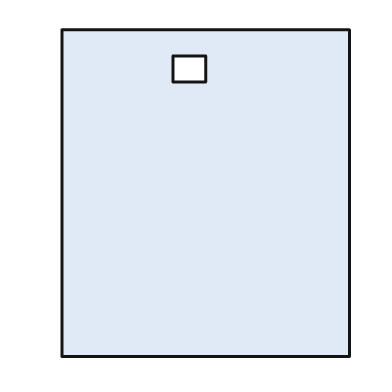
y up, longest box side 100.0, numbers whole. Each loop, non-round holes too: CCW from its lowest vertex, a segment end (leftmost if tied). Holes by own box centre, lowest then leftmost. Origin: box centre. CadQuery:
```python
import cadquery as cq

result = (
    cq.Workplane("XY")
    .moveTo(-44.0, -50.0)
    .lineTo(44.0, -50.0)
    .lineTo(44.0, 50.0)
    .lineTo(-44.0, 50.0)
    .close()
    .moveTo(-10.0, 34.0)
    .lineTo(0.0, 34.0)
    .lineTo(0.0, 42.0)
    .lineTo(-10.0, 42.0)
    .close()
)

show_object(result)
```